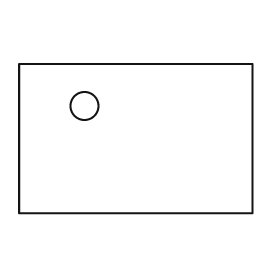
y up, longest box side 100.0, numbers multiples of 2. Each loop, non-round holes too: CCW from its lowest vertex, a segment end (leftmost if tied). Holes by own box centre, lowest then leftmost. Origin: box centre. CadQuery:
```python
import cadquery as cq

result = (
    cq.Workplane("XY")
    .moveTo(-50.0, -32.0)
    .lineTo(50.0, -32.0)
    .lineTo(50.0, 32.0)
    .lineTo(-50.0, 32.0)
    .close()
    .moveTo(-22.0, 14.0)
    .circle(6.0)
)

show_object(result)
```